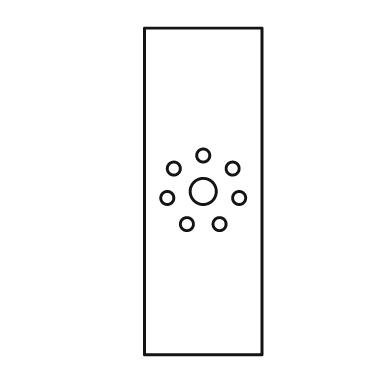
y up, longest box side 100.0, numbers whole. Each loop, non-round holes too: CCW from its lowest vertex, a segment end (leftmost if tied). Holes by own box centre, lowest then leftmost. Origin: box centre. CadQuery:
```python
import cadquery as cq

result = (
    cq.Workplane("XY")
    .moveTo(-18.0, -50.0)
    .lineTo(18.0, -50.0)
    .lineTo(18.0, 50.0)
    .lineTo(-18.0, 50.0)
    .close()
    .moveTo(-5.0, -10.0)
    .circle(2.0)
    .moveTo(5.0, -10.0)
    .circle(2.0)
    .moveTo(-11.0, -2.0)
    .circle(2.0)
    .moveTo(11.0, -2.0)
    .circle(2.0)
    .moveTo(0.0, 0.0)
    .circle(4.0)
    .moveTo(-9.0, 7.0)
    .circle(2.0)
    .moveTo(9.0, 7.0)
    .circle(2.0)
    .moveTo(0.0, 11.0)
    .circle(2.0)
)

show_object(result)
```